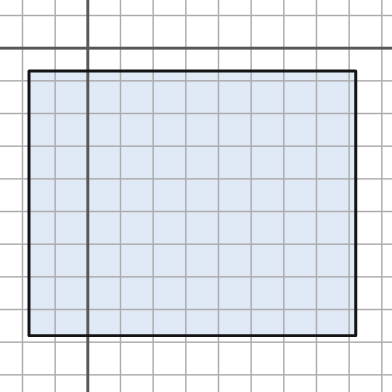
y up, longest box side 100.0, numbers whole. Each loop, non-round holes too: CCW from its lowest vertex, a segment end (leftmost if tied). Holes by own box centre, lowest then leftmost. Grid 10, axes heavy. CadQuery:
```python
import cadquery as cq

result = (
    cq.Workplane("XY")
    .moveTo(-18.0, -88.0)
    .lineTo(82.0, -88.0)
    .lineTo(82.0, -7.0)
    .lineTo(-18.0, -7.0)
    .close()
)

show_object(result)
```